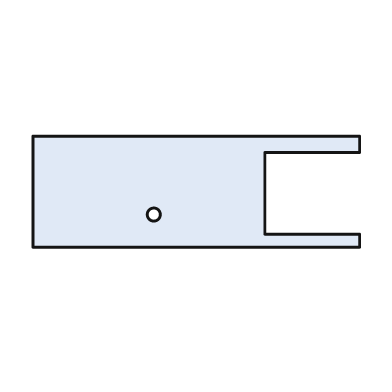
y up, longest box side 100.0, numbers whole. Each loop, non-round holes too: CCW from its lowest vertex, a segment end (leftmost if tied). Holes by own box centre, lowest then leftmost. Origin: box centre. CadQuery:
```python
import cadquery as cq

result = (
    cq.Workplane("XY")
    .moveTo(-50.0, -17.0)
    .lineTo(50.0, -17.0)
    .lineTo(50.0, -13.0)
    .lineTo(21.0, -13.0)
    .lineTo(21.0, 12.0)
    .lineTo(50.0, 12.0)
    .lineTo(50.0, 17.0)
    .lineTo(-50.0, 17.0)
    .close()
    .moveTo(-13.0, -7.0)
    .circle(2.0)
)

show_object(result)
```